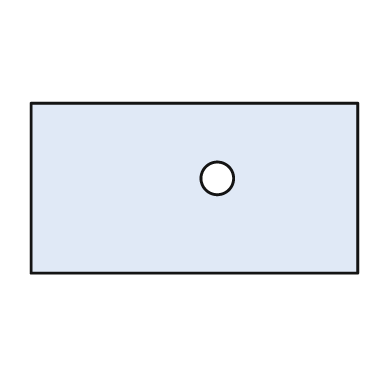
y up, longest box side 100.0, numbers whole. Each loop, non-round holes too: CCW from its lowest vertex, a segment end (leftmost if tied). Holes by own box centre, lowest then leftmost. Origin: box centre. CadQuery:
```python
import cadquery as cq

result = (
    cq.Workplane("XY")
    .moveTo(-50.0, -26.0)
    .lineTo(50.0, -26.0)
    .lineTo(50.0, 26.0)
    .lineTo(-50.0, 26.0)
    .close()
    .moveTo(7.0, 3.0)
    .circle(5.0)
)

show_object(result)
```